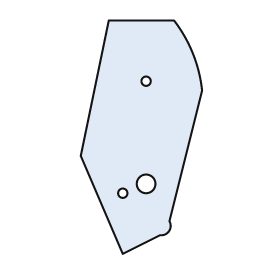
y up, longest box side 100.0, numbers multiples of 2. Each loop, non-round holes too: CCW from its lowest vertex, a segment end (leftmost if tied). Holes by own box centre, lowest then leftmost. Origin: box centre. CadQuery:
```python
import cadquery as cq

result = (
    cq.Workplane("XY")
    .moveTo(-8.0, -50.0)
    .lineTo(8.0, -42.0)
    .threePointArc((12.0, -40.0), (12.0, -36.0))
    .lineTo(26.0, 20.0)
    .threePointArc((22.0, 36.0), (14.0, 50.0))
    .lineTo(-14.0, 50.0)
    .lineTo(-26.0, -8.0)
    .close()
    .moveTo(-8.0, -24.0)
    .circle(2.0)
    .moveTo(2.0, -20.0)
    .circle(4.0)
    .moveTo(2.0, 24.0)
    .circle(2.0)
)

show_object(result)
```